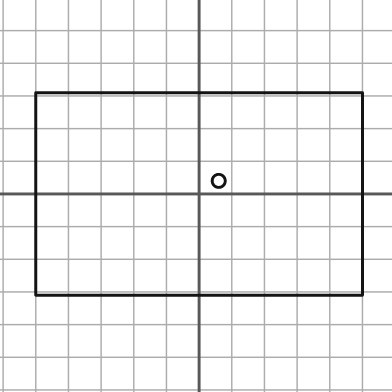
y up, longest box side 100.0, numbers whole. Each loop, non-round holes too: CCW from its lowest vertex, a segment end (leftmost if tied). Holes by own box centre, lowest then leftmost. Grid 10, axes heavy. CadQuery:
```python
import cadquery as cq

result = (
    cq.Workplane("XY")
    .moveTo(-50.0, -31.0)
    .lineTo(50.0, -31.0)
    .lineTo(50.0, 31.0)
    .lineTo(-50.0, 31.0)
    .close()
    .moveTo(6.0, 4.0)
    .circle(2.0)
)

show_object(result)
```